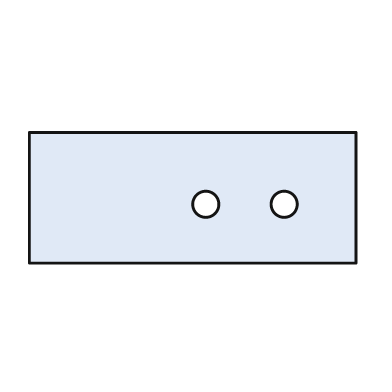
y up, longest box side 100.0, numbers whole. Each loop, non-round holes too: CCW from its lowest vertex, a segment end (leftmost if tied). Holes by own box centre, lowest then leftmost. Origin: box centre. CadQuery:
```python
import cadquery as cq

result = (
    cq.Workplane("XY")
    .moveTo(-50.0, -20.0)
    .lineTo(50.0, -20.0)
    .lineTo(50.0, 20.0)
    .lineTo(-50.0, 20.0)
    .close()
    .moveTo(4.0, -2.0)
    .circle(4.0)
    .moveTo(28.0, -2.0)
    .circle(4.0)
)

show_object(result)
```